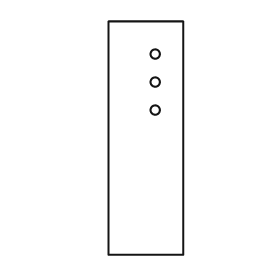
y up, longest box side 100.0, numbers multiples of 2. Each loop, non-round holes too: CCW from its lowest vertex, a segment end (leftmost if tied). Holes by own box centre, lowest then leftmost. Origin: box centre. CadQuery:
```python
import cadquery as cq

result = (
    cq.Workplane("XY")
    .moveTo(-16.0, -50.0)
    .lineTo(16.0, -50.0)
    .lineTo(16.0, 50.0)
    .lineTo(-16.0, 50.0)
    .close()
    .moveTo(4.0, 12.0)
    .circle(2.0)
    .moveTo(4.0, 24.0)
    .circle(2.0)
    .moveTo(4.0, 36.0)
    .circle(2.0)
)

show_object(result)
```